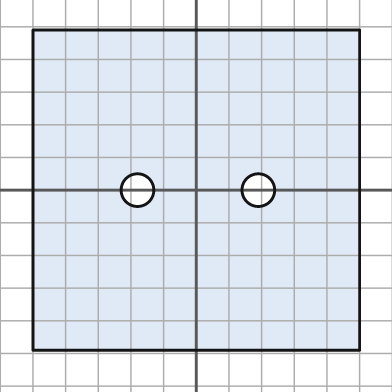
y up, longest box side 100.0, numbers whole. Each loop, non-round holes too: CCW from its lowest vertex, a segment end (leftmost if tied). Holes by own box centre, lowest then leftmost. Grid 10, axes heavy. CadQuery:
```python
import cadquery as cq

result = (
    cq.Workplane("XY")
    .moveTo(-50.0, -49.0)
    .lineTo(50.0, -49.0)
    .lineTo(50.0, 49.0)
    .lineTo(-50.0, 49.0)
    .close()
    .moveTo(-18.0, 0.0)
    .circle(5.0)
    .moveTo(19.0, 0.0)
    .circle(5.0)
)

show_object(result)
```